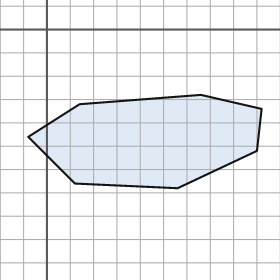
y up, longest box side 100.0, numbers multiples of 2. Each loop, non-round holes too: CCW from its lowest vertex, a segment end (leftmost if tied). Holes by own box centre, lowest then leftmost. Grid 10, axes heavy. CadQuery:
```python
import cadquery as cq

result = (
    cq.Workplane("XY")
    .moveTo(56.0, -68.0)
    .lineTo(90.0, -52.0)
    .lineTo(92.0, -34.0)
    .lineTo(66.0, -28.0)
    .lineTo(14.0, -32.0)
    .lineTo(-8.0, -46.0)
    .lineTo(12.0, -66.0)
    .close()
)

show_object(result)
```